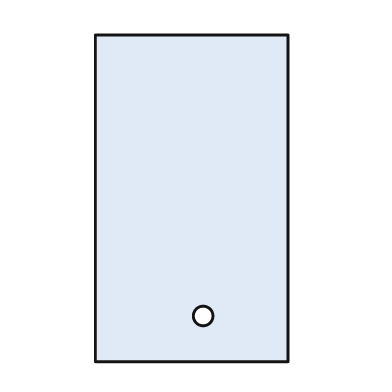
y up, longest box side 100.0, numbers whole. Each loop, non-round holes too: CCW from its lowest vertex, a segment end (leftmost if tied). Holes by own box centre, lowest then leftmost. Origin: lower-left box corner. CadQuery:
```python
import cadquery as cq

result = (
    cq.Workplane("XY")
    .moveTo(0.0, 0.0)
    .lineTo(59.0, 0.0)
    .lineTo(59.0, 100.0)
    .lineTo(0.0, 100.0)
    .close()
    .moveTo(33.0, 14.0)
    .circle(3.0)
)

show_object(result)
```